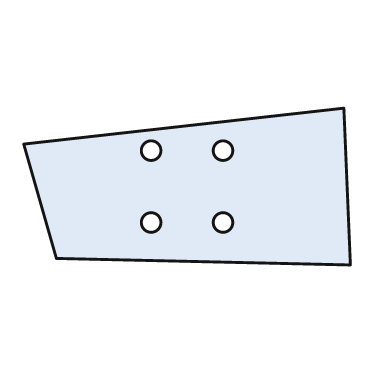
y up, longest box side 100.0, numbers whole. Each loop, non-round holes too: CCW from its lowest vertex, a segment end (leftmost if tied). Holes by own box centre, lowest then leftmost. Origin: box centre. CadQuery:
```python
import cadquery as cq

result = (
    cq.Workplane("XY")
    .moveTo(50.0, -24.0)
    .lineTo(48.0, 24.0)
    .lineTo(-50.0, 13.0)
    .lineTo(-40.0, -22.0)
    .close()
    .moveTo(-11.0, -11.0)
    .circle(3.0)
    .moveTo(11.0, -11.0)
    .circle(3.0)
    .moveTo(-11.0, 11.0)
    .circle(3.0)
    .moveTo(11.0, 11.0)
    .circle(3.0)
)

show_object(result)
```